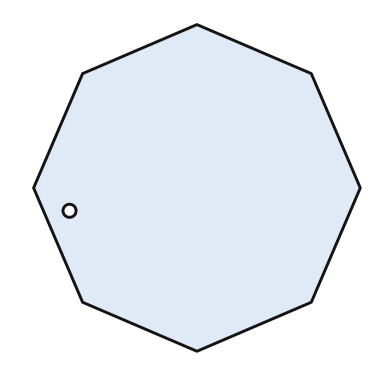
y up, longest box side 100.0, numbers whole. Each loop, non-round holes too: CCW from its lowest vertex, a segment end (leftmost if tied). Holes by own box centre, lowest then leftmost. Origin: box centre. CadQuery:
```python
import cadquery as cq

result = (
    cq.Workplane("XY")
    .moveTo(0.0, -50.0)
    .lineTo(35.0, -35.0)
    .lineTo(50.0, 0.0)
    .lineTo(35.0, 35.0)
    .lineTo(0.0, 50.0)
    .lineTo(-35.0, 35.0)
    .lineTo(-50.0, 0.0)
    .lineTo(-35.0, -35.0)
    .close()
    .moveTo(-39.0, -7.0)
    .circle(2.0)
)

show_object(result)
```